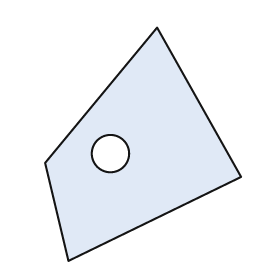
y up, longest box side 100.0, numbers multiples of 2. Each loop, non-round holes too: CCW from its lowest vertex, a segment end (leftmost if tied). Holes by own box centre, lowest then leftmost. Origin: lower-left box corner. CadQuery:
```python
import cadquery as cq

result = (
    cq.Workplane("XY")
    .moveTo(10.0, 0.0)
    .lineTo(84.0, 36.0)
    .lineTo(48.0, 100.0)
    .lineTo(0.0, 42.0)
    .close()
    .moveTo(28.0, 46.0)
    .circle(8.0)
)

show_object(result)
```